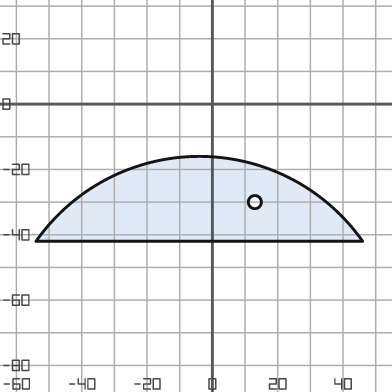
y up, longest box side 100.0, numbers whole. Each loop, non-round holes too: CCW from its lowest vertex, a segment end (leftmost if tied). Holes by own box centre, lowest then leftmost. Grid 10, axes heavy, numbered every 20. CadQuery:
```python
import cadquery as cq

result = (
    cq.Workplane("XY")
    .moveTo(-54.0, -42.0)
    .lineTo(46.0, -42.0)
    .threePointArc((-4.0, -16.0), (-54.0, -42.0))
    .close()
    .moveTo(13.0, -30.0)
    .circle(2.0)
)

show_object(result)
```